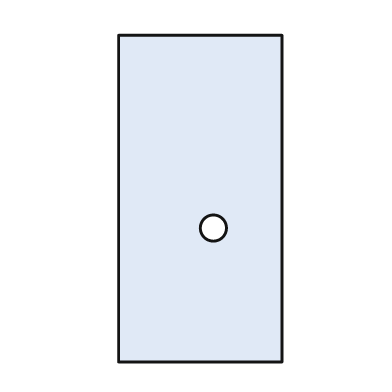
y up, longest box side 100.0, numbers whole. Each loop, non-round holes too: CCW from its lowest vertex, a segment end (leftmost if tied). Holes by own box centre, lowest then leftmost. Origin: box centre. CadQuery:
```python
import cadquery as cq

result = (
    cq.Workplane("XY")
    .moveTo(-25.0, -50.0)
    .lineTo(25.0, -50.0)
    .lineTo(25.0, 50.0)
    .lineTo(-25.0, 50.0)
    .close()
    .moveTo(4.0, -9.0)
    .circle(4.0)
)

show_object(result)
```